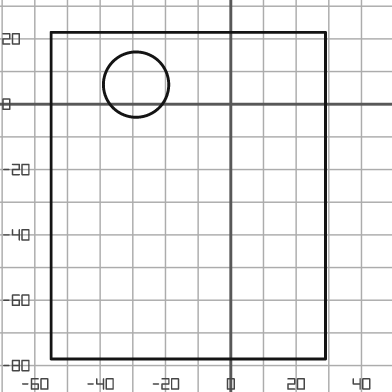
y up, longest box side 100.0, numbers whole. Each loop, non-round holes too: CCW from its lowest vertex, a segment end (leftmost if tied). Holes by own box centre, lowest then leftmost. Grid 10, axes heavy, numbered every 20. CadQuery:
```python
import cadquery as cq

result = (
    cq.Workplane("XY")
    .moveTo(-55.0, -78.0)
    .lineTo(29.0, -78.0)
    .lineTo(29.0, 22.0)
    .lineTo(-55.0, 22.0)
    .close()
    .moveTo(-29.0, 6.0)
    .circle(10.0)
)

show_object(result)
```